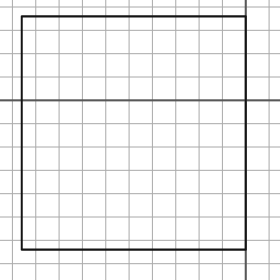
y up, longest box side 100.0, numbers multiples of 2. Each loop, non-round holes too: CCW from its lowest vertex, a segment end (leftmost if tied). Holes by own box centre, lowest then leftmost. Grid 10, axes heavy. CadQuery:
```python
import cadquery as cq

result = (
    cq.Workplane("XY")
    .moveTo(-96.0, -64.0)
    .lineTo(0.0, -64.0)
    .lineTo(0.0, 36.0)
    .lineTo(-96.0, 36.0)
    .close()
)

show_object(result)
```